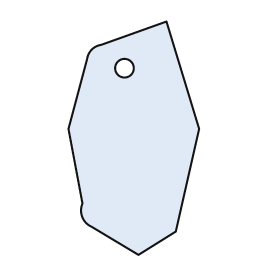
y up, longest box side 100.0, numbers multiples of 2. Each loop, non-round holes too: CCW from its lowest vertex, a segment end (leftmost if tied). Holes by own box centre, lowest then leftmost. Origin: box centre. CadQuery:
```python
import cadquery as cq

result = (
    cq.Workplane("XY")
    .moveTo(2.0, -50.0)
    .lineTo(18.0, -40.0)
    .lineTo(28.0, 4.0)
    .lineTo(14.0, 50.0)
    .lineTo(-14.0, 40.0)
    .threePointArc((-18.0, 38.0), (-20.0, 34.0))
    .lineTo(-28.0, 4.0)
    .lineTo(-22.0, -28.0)
    .threePointArc((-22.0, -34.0), (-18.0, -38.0))
    .close()
    .moveTo(-4.0, 30.0)
    .circle(4.0)
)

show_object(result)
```